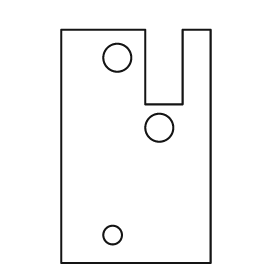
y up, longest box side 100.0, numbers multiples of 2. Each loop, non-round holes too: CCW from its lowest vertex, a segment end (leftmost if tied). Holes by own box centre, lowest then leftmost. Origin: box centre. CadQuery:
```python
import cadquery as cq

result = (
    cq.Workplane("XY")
    .moveTo(-32.0, -50.0)
    .lineTo(32.0, -50.0)
    .lineTo(32.0, 50.0)
    .lineTo(20.0, 50.0)
    .lineTo(20.0, 18.0)
    .lineTo(4.0, 18.0)
    .lineTo(4.0, 50.0)
    .lineTo(-32.0, 50.0)
    .close()
    .moveTo(-10.0, -38.0)
    .circle(4.0)
    .moveTo(10.0, 8.0)
    .circle(6.0)
    .moveTo(-8.0, 38.0)
    .circle(6.0)
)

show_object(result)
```